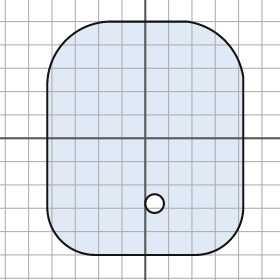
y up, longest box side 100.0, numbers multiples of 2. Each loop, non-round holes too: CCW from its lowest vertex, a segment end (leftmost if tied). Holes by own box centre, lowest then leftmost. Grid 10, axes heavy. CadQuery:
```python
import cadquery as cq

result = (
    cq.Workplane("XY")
    .moveTo(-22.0, -50.0)
    .lineTo(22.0, -50.0)
    .threePointArc((36.0, -44.0), (42.0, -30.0))
    .lineTo(42.0, 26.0)
    .threePointArc((34.0, 42.0), (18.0, 50.0))
    .lineTo(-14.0, 50.0)
    .threePointArc((-34.0, 42.0), (-42.0, 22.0))
    .lineTo(-42.0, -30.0)
    .threePointArc((-36.0, -44.0), (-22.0, -50.0))
    .close()
    .moveTo(4.0, -28.0)
    .circle(4.0)
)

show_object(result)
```